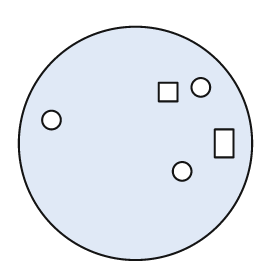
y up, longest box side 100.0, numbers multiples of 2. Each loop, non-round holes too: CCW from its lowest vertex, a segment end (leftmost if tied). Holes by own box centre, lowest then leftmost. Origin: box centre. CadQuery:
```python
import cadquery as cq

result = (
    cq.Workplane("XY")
    .moveTo(0.0, 0.0)
    .circle(50.0)
    .moveTo(20.0, -12.0)
    .circle(4.0)
    .moveTo(34.0, -6.0)
    .lineTo(42.0, -6.0)
    .lineTo(42.0, 6.0)
    .lineTo(34.0, 6.0)
    .close()
    .moveTo(-36.0, 10.0)
    .circle(4.0)
    .moveTo(10.0, 18.0)
    .lineTo(18.0, 18.0)
    .lineTo(18.0, 26.0)
    .lineTo(10.0, 26.0)
    .close()
    .moveTo(28.0, 24.0)
    .circle(4.0)
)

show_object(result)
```